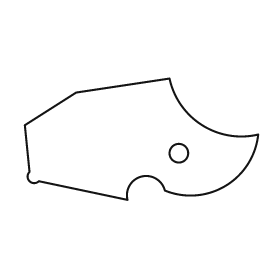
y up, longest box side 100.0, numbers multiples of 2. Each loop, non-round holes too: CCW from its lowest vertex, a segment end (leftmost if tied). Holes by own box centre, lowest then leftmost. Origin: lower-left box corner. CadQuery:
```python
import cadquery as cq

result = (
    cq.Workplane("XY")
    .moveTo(44.0, 0.0)
    .threePointArc((50.0, 10.0), (60.0, 4.0))
    .threePointArc((86.0, 6.0), (100.0, 28.0))
    .threePointArc((76.0, 32.0), (62.0, 52.0))
    .lineTo(22.0, 46.0)
    .lineTo(0.0, 32.0)
    .lineTo(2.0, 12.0)
    .threePointArc((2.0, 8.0), (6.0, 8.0))
    .close()
    .moveTo(66.0, 20.0)
    .circle(4.0)
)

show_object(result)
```